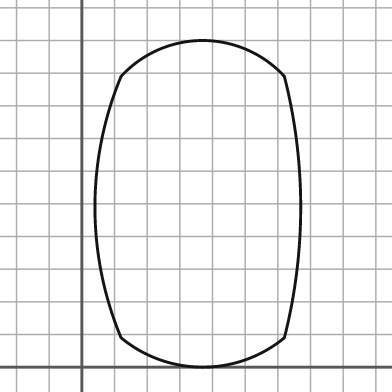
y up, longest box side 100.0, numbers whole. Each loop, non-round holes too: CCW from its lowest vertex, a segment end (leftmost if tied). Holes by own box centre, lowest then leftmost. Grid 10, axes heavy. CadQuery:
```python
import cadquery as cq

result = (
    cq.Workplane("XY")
    .moveTo(12.0, 9.0)
    .threePointArc((37.0, 0.0), (62.0, 9.0))
    .threePointArc((67.0, 49.0), (62.0, 89.0))
    .threePointArc((37.0, 100.0), (12.0, 89.0))
    .threePointArc((4.0, 49.0), (12.0, 9.0))
    .close()
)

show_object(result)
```